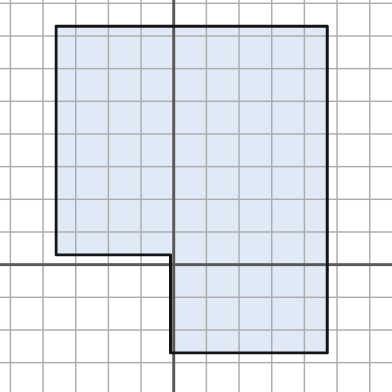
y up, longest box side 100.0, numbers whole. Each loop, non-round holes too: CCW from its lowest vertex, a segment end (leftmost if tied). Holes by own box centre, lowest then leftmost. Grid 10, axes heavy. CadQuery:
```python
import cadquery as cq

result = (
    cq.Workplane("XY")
    .moveTo(-1.0, -27.0)
    .lineTo(47.0, -27.0)
    .lineTo(47.0, 73.0)
    .lineTo(-36.0, 73.0)
    .lineTo(-36.0, 3.0)
    .lineTo(-1.0, 3.0)
    .close()
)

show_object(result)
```